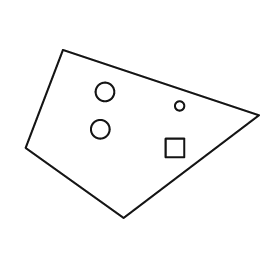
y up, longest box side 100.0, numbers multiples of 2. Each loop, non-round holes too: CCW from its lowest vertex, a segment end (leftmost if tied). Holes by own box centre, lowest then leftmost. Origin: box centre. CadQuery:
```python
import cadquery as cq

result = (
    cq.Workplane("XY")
    .moveTo(-8.0, -36.0)
    .lineTo(50.0, 8.0)
    .lineTo(-34.0, 36.0)
    .lineTo(-50.0, -6.0)
    .close()
    .moveTo(10.0, -10.0)
    .lineTo(18.0, -10.0)
    .lineTo(18.0, -2.0)
    .lineTo(10.0, -2.0)
    .close()
    .moveTo(-18.0, 2.0)
    .circle(4.0)
    .moveTo(16.0, 12.0)
    .circle(2.0)
    .moveTo(-16.0, 18.0)
    .circle(4.0)
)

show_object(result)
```